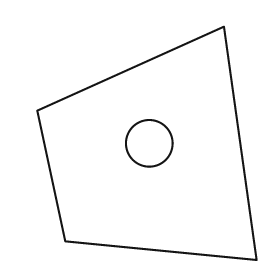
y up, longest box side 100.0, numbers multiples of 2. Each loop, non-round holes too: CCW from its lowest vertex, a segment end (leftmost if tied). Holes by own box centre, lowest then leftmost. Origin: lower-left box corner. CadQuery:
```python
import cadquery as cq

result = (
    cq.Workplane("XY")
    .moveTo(94.0, 0.0)
    .lineTo(80.0, 100.0)
    .lineTo(0.0, 64.0)
    .lineTo(12.0, 8.0)
    .close()
    .moveTo(48.0, 50.0)
    .circle(10.0)
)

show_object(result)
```